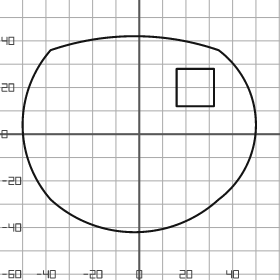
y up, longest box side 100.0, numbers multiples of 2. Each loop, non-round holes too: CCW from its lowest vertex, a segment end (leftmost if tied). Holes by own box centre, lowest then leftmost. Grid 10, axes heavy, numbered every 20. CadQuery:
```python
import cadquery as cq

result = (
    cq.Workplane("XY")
    .moveTo(-38.0, -28.0)
    .threePointArc((-2.0, -42.0), (34.0, -28.0))
    .threePointArc((50.0, 4.0), (34.0, 36.0))
    .threePointArc((-2.0, 42.0), (-38.0, 36.0))
    .threePointArc((-50.0, 4.0), (-38.0, -28.0))
    .close()
    .moveTo(16.0, 12.0)
    .lineTo(32.0, 12.0)
    .lineTo(32.0, 28.0)
    .lineTo(16.0, 28.0)
    .close()
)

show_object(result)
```